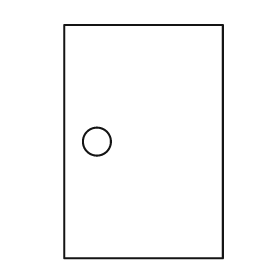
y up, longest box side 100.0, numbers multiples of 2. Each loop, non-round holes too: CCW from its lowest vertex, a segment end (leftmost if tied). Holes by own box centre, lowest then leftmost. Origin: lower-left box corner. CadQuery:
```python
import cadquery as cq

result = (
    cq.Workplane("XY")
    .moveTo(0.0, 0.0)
    .lineTo(68.0, 0.0)
    .lineTo(68.0, 100.0)
    .lineTo(0.0, 100.0)
    .close()
    .moveTo(14.0, 50.0)
    .circle(6.0)
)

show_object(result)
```